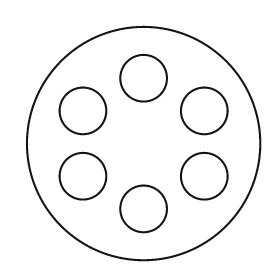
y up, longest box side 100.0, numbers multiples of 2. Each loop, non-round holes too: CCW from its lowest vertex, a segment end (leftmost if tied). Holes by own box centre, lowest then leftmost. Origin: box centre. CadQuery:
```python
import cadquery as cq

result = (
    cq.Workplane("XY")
    .moveTo(0.0, 0.0)
    .circle(50.0)
    .moveTo(0.0, -28.0)
    .circle(10.0)
    .moveTo(-26.0, -14.0)
    .circle(10.0)
    .moveTo(26.0, -14.0)
    .circle(10.0)
    .moveTo(-26.0, 14.0)
    .circle(10.0)
    .moveTo(26.0, 14.0)
    .circle(10.0)
    .moveTo(0.0, 28.0)
    .circle(10.0)
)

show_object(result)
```